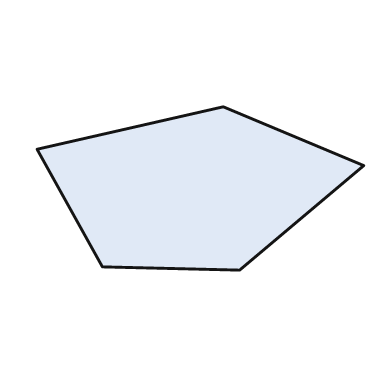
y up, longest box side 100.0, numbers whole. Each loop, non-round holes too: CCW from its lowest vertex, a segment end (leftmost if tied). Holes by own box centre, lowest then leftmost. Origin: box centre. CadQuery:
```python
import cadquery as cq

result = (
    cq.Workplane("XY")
    .moveTo(12.0, -25.0)
    .lineTo(50.0, 7.0)
    .lineTo(7.0, 25.0)
    .lineTo(-50.0, 12.0)
    .lineTo(-30.0, -24.0)
    .close()
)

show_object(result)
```